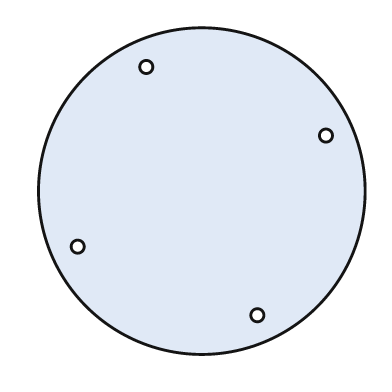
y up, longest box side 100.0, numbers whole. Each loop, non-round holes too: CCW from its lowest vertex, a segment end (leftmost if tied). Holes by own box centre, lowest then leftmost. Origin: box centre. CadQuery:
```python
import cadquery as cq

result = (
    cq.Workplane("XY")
    .moveTo(0.0, 0.0)
    .circle(50.0)
    .moveTo(17.0, -38.0)
    .circle(2.0)
    .moveTo(-38.0, -17.0)
    .circle(2.0)
    .moveTo(38.0, 17.0)
    .circle(2.0)
    .moveTo(-17.0, 38.0)
    .circle(2.0)
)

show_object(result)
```